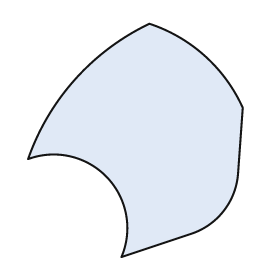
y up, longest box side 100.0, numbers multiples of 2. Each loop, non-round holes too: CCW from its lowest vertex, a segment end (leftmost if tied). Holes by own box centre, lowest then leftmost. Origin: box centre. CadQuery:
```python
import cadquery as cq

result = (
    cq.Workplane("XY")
    .moveTo(-6.0, -50.0)
    .lineTo(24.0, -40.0)
    .threePointArc((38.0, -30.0), (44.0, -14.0))
    .lineTo(46.0, 14.0)
    .threePointArc((30.0, 36.0), (6.0, 50.0))
    .threePointArc((-26.0, 26.0), (-46.0, -8.0))
    .threePointArc((-12.0, -16.0), (-6.0, -50.0))
    .close()
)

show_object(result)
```